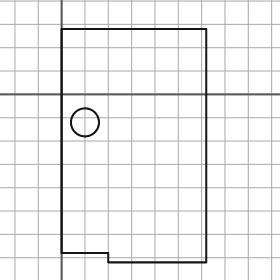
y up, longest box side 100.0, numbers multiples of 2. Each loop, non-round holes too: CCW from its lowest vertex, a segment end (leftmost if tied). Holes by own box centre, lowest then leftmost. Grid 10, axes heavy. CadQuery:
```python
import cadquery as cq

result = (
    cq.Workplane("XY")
    .moveTo(20.0, -72.0)
    .lineTo(62.0, -72.0)
    .lineTo(62.0, 28.0)
    .lineTo(0.0, 28.0)
    .lineTo(0.0, -68.0)
    .lineTo(20.0, -68.0)
    .close()
    .moveTo(10.0, -12.0)
    .circle(6.0)
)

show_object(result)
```